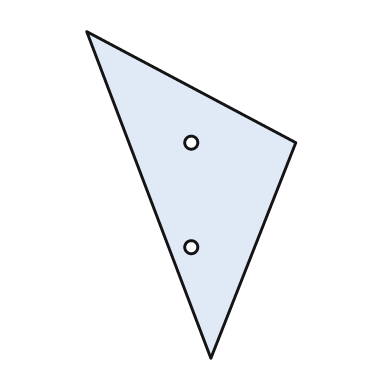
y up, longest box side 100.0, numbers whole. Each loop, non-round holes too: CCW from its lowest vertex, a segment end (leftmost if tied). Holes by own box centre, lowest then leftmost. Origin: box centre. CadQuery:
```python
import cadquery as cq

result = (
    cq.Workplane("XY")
    .moveTo(6.0, -50.0)
    .lineTo(32.0, 16.0)
    .lineTo(-32.0, 50.0)
    .close()
    .moveTo(0.0, -16.0)
    .circle(2.0)
    .moveTo(0.0, 16.0)
    .circle(2.0)
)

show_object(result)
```